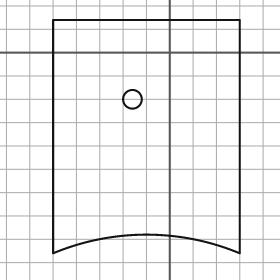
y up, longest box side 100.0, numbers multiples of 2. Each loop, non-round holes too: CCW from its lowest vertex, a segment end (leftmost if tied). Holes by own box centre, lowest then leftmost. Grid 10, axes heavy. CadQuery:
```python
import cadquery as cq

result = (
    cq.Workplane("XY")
    .moveTo(-50.0, -86.0)
    .threePointArc((-10.0, -78.0), (30.0, -86.0))
    .lineTo(30.0, 14.0)
    .lineTo(-50.0, 14.0)
    .close()
    .moveTo(-16.0, -20.0)
    .circle(4.0)
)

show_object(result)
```